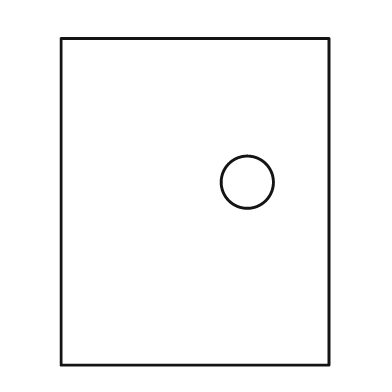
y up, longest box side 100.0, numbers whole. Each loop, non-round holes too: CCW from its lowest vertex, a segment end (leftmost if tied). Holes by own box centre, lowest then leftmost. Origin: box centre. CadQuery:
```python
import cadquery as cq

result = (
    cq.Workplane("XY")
    .moveTo(-41.0, -50.0)
    .lineTo(41.0, -50.0)
    .lineTo(41.0, 50.0)
    .lineTo(-41.0, 50.0)
    .close()
    .moveTo(16.0, 6.0)
    .circle(8.0)
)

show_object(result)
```